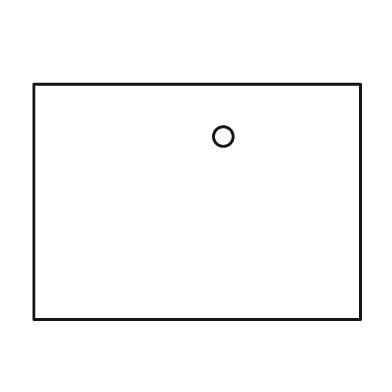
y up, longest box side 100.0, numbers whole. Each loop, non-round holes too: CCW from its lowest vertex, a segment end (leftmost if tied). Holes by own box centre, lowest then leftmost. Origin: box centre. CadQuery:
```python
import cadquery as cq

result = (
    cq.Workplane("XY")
    .moveTo(-50.0, -36.0)
    .lineTo(50.0, -36.0)
    .lineTo(50.0, 36.0)
    .lineTo(-50.0, 36.0)
    .close()
    .moveTo(8.0, 20.0)
    .circle(3.0)
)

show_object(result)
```